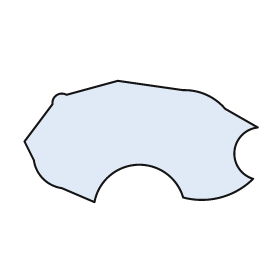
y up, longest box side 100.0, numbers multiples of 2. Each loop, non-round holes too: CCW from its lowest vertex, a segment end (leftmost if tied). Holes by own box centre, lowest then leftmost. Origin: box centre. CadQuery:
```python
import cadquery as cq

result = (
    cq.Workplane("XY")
    .moveTo(-20.0, -26.0)
    .threePointArc((-2.0, -10.0), (18.0, -24.0))
    .threePointArc((34.0, -24.0), (48.0, -16.0))
    .threePointArc((40.0, -4.0), (50.0, 6.0))
    .lineTo(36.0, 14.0)
    .threePointArc((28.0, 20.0), (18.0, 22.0))
    .lineTo(-10.0, 26.0)
    .lineTo(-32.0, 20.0)
    .threePointArc((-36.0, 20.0), (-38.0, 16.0))
    .lineTo(-50.0, 0.0)
    .lineTo(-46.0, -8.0)
    .threePointArc((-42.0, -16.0), (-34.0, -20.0))
    .close()
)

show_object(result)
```